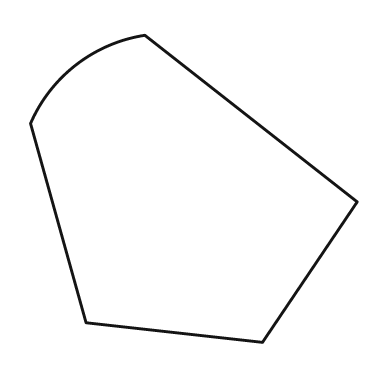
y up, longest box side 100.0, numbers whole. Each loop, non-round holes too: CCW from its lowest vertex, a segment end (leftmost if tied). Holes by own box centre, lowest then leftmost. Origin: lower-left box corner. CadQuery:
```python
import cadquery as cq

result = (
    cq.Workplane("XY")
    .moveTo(71.0, 0.0)
    .lineTo(100.0, 43.0)
    .lineTo(35.0, 94.0)
    .threePointArc((14.0, 85.0), (0.0, 67.0))
    .lineTo(17.0, 6.0)
    .close()
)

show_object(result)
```